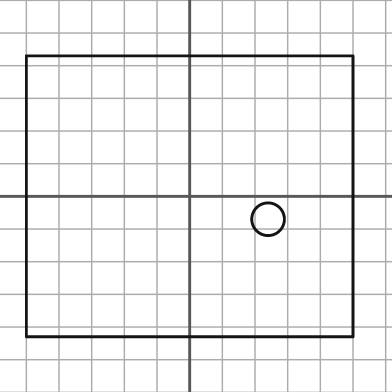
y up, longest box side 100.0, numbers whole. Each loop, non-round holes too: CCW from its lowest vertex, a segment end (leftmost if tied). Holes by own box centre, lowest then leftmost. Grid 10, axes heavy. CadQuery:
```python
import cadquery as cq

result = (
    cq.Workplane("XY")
    .moveTo(-50.0, -43.0)
    .lineTo(50.0, -43.0)
    .lineTo(50.0, 43.0)
    .lineTo(-50.0, 43.0)
    .close()
    .moveTo(24.0, -7.0)
    .circle(5.0)
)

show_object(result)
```